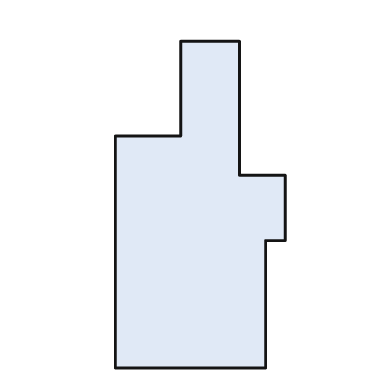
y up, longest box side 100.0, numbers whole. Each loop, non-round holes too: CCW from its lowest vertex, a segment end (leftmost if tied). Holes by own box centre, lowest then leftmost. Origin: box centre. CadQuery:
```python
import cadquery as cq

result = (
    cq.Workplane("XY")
    .moveTo(-26.0, -50.0)
    .lineTo(20.0, -50.0)
    .lineTo(20.0, -11.0)
    .lineTo(26.0, -11.0)
    .lineTo(26.0, 9.0)
    .lineTo(12.0, 9.0)
    .lineTo(12.0, 50.0)
    .lineTo(-6.0, 50.0)
    .lineTo(-6.0, 21.0)
    .lineTo(-26.0, 21.0)
    .close()
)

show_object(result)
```